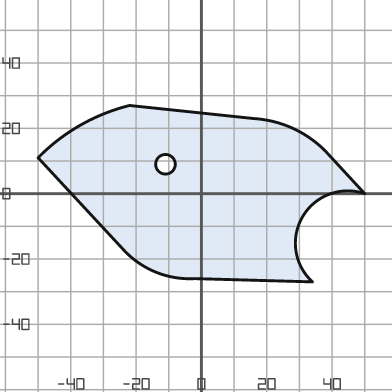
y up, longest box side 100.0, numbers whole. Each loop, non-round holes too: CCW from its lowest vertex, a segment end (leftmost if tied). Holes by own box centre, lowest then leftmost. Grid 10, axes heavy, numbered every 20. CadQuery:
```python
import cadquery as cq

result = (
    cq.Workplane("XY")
    .moveTo(34.0, -27.0)
    .threePointArc((31.0, -7.0), (50.0, 0.0))
    .lineTo(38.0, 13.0)
    .threePointArc((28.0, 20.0), (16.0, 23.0))
    .lineTo(-22.0, 27.0)
    .threePointArc((-37.0, 21.0), (-50.0, 11.0))
    .lineTo(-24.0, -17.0)
    .threePointArc((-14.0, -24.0), (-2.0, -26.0))
    .close()
    .moveTo(-11.0, 9.0)
    .circle(3.0)
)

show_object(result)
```